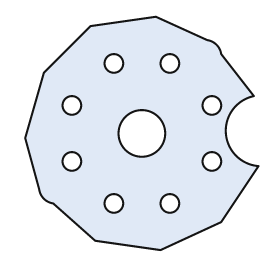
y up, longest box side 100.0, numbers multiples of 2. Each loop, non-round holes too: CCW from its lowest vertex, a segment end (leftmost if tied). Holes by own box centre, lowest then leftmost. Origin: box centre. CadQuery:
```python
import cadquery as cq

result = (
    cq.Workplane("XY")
    .moveTo(8.0, -50.0)
    .lineTo(34.0, -38.0)
    .lineTo(50.0, -14.0)
    .threePointArc((36.0, 0.0), (48.0, 16.0))
    .lineTo(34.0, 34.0)
    .threePointArc((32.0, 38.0), (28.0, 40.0))
    .lineTo(6.0, 50.0)
    .lineTo(-22.0, 46.0)
    .lineTo(-42.0, 26.0)
    .lineTo(-50.0, -2.0)
    .lineTo(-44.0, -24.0)
    .threePointArc((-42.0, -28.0), (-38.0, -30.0))
    .lineTo(-20.0, -46.0)
    .close()
    .moveTo(-12.0, -30.0)
    .circle(4.0)
    .moveTo(12.0, -30.0)
    .circle(4.0)
    .moveTo(-30.0, -12.0)
    .circle(4.0)
    .moveTo(30.0, -12.0)
    .circle(4.0)
    .moveTo(0.0, 0.0)
    .circle(10.0)
    .moveTo(-30.0, 12.0)
    .circle(4.0)
    .moveTo(30.0, 12.0)
    .circle(4.0)
    .moveTo(-12.0, 30.0)
    .circle(4.0)
    .moveTo(12.0, 30.0)
    .circle(4.0)
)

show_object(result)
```